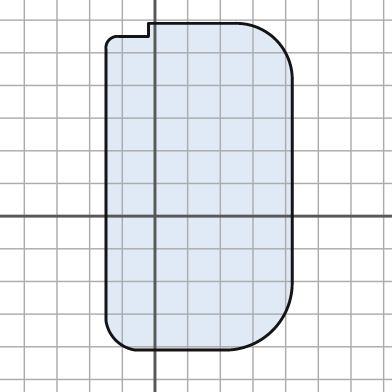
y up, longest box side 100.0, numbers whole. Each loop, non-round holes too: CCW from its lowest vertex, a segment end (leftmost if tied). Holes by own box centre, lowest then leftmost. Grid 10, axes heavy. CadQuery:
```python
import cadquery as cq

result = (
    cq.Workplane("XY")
    .moveTo(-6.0, -41.0)
    .lineTo(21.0, -41.0)
    .threePointArc((36.0, -35.0), (42.0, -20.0))
    .lineTo(42.0, 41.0)
    .threePointArc((37.0, 54.0), (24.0, 59.0))
    .lineTo(-2.0, 59.0)
    .lineTo(-2.0, 55.0)
    .lineTo(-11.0, 55.0)
    .threePointArc((-14.0, 54.0), (-15.0, 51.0))
    .lineTo(-15.0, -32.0)
    .threePointArc((-12.0, -38.0), (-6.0, -41.0))
    .close()
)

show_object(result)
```